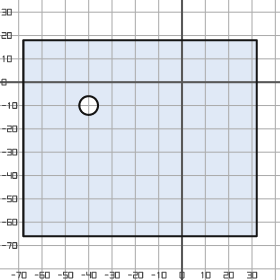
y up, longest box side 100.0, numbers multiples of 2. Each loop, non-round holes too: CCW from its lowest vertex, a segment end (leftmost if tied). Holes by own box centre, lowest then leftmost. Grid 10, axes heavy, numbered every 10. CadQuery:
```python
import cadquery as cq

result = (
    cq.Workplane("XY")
    .moveTo(-68.0, -66.0)
    .lineTo(32.0, -66.0)
    .lineTo(32.0, 18.0)
    .lineTo(-68.0, 18.0)
    .close()
    .moveTo(-40.0, -10.0)
    .circle(4.0)
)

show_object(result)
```